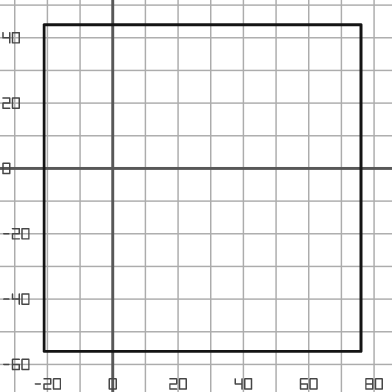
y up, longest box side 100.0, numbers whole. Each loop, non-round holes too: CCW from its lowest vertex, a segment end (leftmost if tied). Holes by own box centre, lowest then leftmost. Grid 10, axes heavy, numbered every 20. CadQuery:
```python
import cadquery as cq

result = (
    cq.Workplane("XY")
    .moveTo(-21.0, -56.0)
    .lineTo(76.0, -56.0)
    .lineTo(76.0, 44.0)
    .lineTo(-21.0, 44.0)
    .close()
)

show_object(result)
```